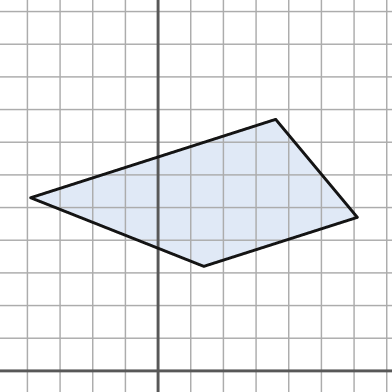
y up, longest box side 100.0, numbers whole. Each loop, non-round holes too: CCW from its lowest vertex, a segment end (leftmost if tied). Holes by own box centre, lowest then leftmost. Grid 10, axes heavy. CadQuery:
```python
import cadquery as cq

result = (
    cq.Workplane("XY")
    .moveTo(14.0, 32.0)
    .lineTo(61.0, 47.0)
    .lineTo(36.0, 77.0)
    .lineTo(-39.0, 53.0)
    .close()
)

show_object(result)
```